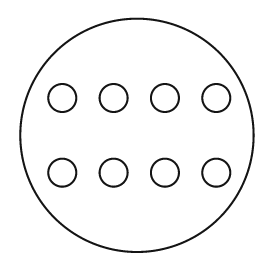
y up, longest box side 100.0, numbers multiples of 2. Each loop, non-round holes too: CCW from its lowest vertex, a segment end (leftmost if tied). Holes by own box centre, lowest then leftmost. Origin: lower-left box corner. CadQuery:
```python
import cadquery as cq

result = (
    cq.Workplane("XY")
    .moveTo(50.0, 50.0)
    .circle(50.0)
    .moveTo(18.0, 34.0)
    .circle(6.0)
    .moveTo(40.0, 34.0)
    .circle(6.0)
    .moveTo(62.0, 34.0)
    .circle(6.0)
    .moveTo(84.0, 34.0)
    .circle(6.0)
    .moveTo(18.0, 66.0)
    .circle(6.0)
    .moveTo(40.0, 66.0)
    .circle(6.0)
    .moveTo(62.0, 66.0)
    .circle(6.0)
    .moveTo(84.0, 66.0)
    .circle(6.0)
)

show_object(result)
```